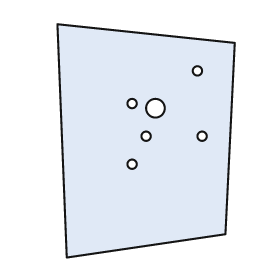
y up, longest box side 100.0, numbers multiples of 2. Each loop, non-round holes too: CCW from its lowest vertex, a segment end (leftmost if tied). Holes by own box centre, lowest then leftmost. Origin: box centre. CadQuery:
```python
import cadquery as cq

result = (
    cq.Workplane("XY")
    .moveTo(-34.0, -50.0)
    .lineTo(34.0, -40.0)
    .lineTo(38.0, 42.0)
    .lineTo(-38.0, 50.0)
    .close()
    .moveTo(-6.0, -10.0)
    .circle(2.0)
    .moveTo(0.0, 2.0)
    .circle(2.0)
    .moveTo(24.0, 2.0)
    .circle(2.0)
    .moveTo(4.0, 14.0)
    .circle(4.0)
    .moveTo(-6.0, 16.0)
    .circle(2.0)
    .moveTo(22.0, 30.0)
    .circle(2.0)
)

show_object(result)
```